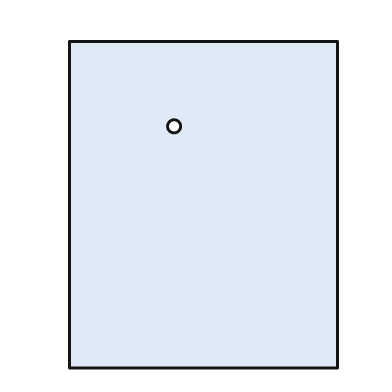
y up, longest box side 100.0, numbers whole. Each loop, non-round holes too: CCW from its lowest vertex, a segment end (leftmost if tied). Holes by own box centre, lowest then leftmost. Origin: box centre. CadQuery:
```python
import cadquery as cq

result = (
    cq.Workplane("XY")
    .moveTo(-41.0, -50.0)
    .lineTo(41.0, -50.0)
    .lineTo(41.0, 50.0)
    .lineTo(-41.0, 50.0)
    .close()
    .moveTo(-9.0, 24.0)
    .circle(2.0)
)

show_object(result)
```